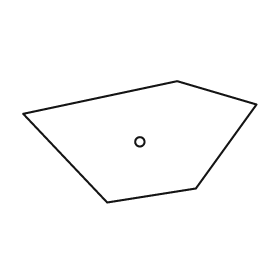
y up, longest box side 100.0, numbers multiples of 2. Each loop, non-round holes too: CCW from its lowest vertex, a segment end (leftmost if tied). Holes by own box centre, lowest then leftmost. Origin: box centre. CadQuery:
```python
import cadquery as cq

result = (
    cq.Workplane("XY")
    .moveTo(-14.0, -26.0)
    .lineTo(24.0, -20.0)
    .lineTo(50.0, 16.0)
    .lineTo(16.0, 26.0)
    .lineTo(-50.0, 12.0)
    .close()
    .moveTo(0.0, 0.0)
    .circle(2.0)
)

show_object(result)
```